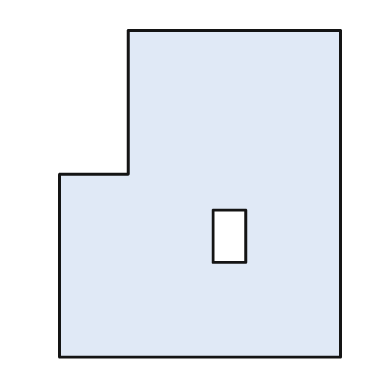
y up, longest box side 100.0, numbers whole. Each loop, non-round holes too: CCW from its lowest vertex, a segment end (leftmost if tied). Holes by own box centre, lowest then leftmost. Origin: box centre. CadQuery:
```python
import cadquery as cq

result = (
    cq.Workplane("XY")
    .moveTo(-43.0, -50.0)
    .lineTo(43.0, -50.0)
    .lineTo(43.0, 50.0)
    .lineTo(-22.0, 50.0)
    .lineTo(-22.0, 6.0)
    .lineTo(-43.0, 6.0)
    .close()
    .moveTo(4.0, -21.0)
    .lineTo(14.0, -21.0)
    .lineTo(14.0, -5.0)
    .lineTo(4.0, -5.0)
    .close()
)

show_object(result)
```